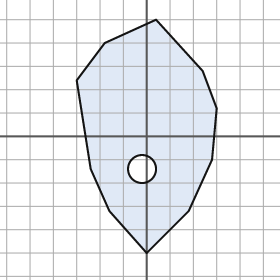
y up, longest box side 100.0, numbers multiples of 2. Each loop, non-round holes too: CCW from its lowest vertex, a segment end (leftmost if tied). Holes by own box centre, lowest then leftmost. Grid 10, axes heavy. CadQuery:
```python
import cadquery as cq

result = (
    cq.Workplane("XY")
    .moveTo(0.0, -50.0)
    .lineTo(18.0, -32.0)
    .lineTo(28.0, -10.0)
    .lineTo(30.0, 12.0)
    .lineTo(24.0, 28.0)
    .lineTo(4.0, 50.0)
    .lineTo(-18.0, 40.0)
    .lineTo(-30.0, 24.0)
    .lineTo(-24.0, -14.0)
    .lineTo(-16.0, -32.0)
    .close()
    .moveTo(-2.0, -14.0)
    .circle(6.0)
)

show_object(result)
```